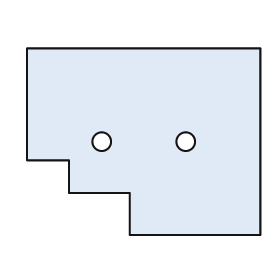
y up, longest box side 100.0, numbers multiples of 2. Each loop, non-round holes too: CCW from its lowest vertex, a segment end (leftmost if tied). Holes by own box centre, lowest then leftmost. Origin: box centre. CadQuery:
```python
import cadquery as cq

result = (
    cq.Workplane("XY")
    .moveTo(-6.0, -40.0)
    .lineTo(50.0, -40.0)
    .lineTo(50.0, 40.0)
    .lineTo(-50.0, 40.0)
    .lineTo(-50.0, -8.0)
    .lineTo(-32.0, -8.0)
    .lineTo(-32.0, -22.0)
    .lineTo(-6.0, -22.0)
    .close()
    .moveTo(-18.0, 0.0)
    .circle(4.0)
    .moveTo(18.0, 0.0)
    .circle(4.0)
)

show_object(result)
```